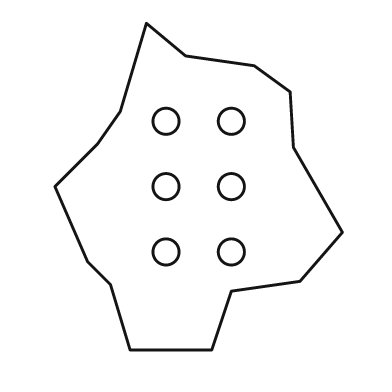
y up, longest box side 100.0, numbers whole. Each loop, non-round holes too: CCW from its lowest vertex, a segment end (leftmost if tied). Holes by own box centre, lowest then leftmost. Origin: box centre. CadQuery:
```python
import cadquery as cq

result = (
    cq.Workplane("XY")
    .moveTo(-21.0, -50.0)
    .lineTo(4.0, -50.0)
    .lineTo(10.0, -32.0)
    .lineTo(31.0, -29.0)
    .lineTo(44.0, -14.0)
    .lineTo(29.0, 12.0)
    .lineTo(28.0, 29.0)
    .lineTo(17.0, 37.0)
    .lineTo(-4.0, 40.0)
    .lineTo(-16.0, 50.0)
    .lineTo(-24.0, 23.0)
    .lineTo(-31.0, 13.0)
    .lineTo(-44.0, 0.0)
    .lineTo(-34.0, -23.0)
    .lineTo(-27.0, -30.0)
    .close()
    .moveTo(-10.0, -20.0)
    .circle(4.0)
    .moveTo(10.0, -20.0)
    .circle(4.0)
    .moveTo(-10.0, 0.0)
    .circle(4.0)
    .moveTo(10.0, 0.0)
    .circle(4.0)
    .moveTo(-10.0, 20.0)
    .circle(4.0)
    .moveTo(10.0, 20.0)
    .circle(4.0)
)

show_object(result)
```